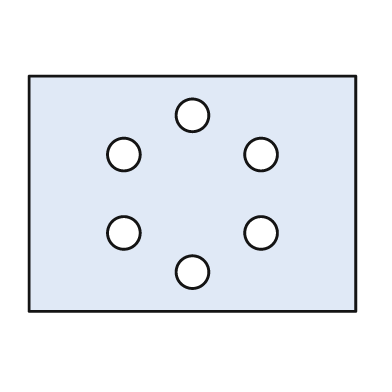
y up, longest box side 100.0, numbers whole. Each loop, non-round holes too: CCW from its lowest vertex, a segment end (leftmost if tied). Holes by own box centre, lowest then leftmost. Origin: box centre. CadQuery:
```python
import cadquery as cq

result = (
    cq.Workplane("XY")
    .moveTo(-50.0, -36.0)
    .lineTo(50.0, -36.0)
    .lineTo(50.0, 36.0)
    .lineTo(-50.0, 36.0)
    .close()
    .moveTo(0.0, -24.0)
    .circle(5.0)
    .moveTo(-21.0, -12.0)
    .circle(5.0)
    .moveTo(21.0, -12.0)
    .circle(5.0)
    .moveTo(-21.0, 12.0)
    .circle(5.0)
    .moveTo(21.0, 12.0)
    .circle(5.0)
    .moveTo(0.0, 24.0)
    .circle(5.0)
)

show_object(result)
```